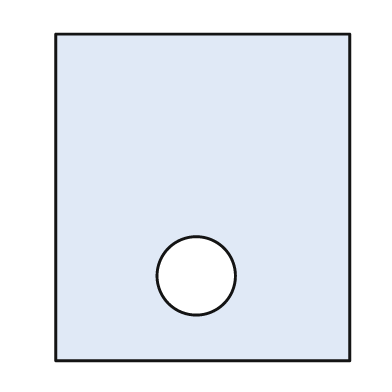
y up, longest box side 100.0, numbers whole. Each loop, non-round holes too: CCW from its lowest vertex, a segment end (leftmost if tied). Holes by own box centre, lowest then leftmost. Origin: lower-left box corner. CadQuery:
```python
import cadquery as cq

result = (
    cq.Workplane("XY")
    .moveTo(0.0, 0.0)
    .lineTo(90.0, 0.0)
    .lineTo(90.0, 100.0)
    .lineTo(0.0, 100.0)
    .close()
    .moveTo(43.0, 26.0)
    .circle(12.0)
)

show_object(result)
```